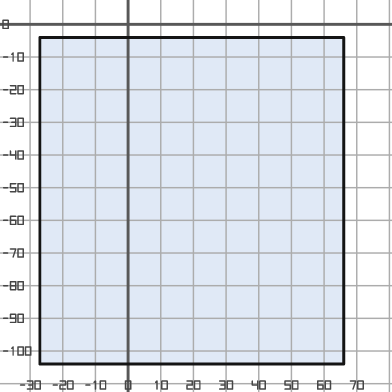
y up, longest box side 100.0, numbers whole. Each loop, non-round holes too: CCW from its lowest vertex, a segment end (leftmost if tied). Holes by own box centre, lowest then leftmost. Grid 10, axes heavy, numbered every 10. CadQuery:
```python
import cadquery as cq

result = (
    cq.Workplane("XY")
    .moveTo(-27.0, -104.0)
    .lineTo(66.0, -104.0)
    .lineTo(66.0, -4.0)
    .lineTo(-27.0, -4.0)
    .close()
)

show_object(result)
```